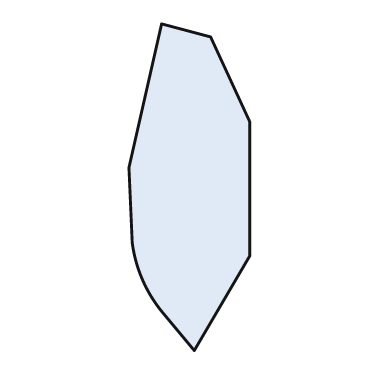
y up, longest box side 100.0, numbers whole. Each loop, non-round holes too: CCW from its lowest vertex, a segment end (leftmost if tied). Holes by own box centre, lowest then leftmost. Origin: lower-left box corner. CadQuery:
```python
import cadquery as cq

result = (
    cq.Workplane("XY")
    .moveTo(20.0, 0.0)
    .lineTo(37.0, 29.0)
    .lineTo(37.0, 70.0)
    .lineTo(25.0, 96.0)
    .lineTo(10.0, 100.0)
    .lineTo(0.0, 56.0)
    .lineTo(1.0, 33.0)
    .threePointArc((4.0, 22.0), (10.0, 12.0))
    .close()
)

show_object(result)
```